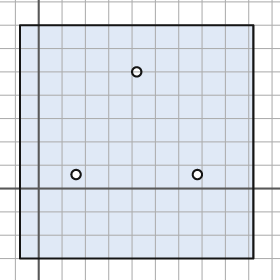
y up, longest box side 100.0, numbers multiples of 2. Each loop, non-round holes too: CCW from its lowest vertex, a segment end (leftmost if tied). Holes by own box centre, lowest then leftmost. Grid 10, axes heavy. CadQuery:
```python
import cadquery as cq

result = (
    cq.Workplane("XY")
    .moveTo(-8.0, -30.0)
    .lineTo(92.0, -30.0)
    .lineTo(92.0, 70.0)
    .lineTo(-8.0, 70.0)
    .close()
    .moveTo(16.0, 6.0)
    .circle(2.0)
    .moveTo(68.0, 6.0)
    .circle(2.0)
    .moveTo(42.0, 50.0)
    .circle(2.0)
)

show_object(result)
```